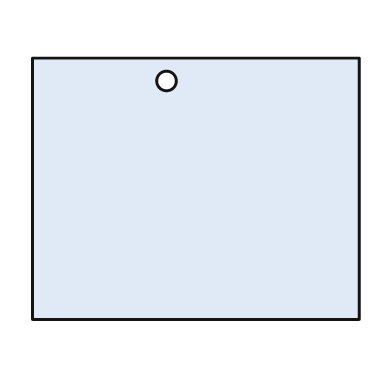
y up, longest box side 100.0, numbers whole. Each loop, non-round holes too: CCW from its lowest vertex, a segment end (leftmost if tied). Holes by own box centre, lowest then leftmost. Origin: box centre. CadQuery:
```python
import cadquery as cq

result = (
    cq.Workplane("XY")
    .moveTo(-50.0, -40.0)
    .lineTo(50.0, -40.0)
    .lineTo(50.0, 40.0)
    .lineTo(-50.0, 40.0)
    .close()
    .moveTo(-9.0, 33.0)
    .circle(3.0)
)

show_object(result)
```